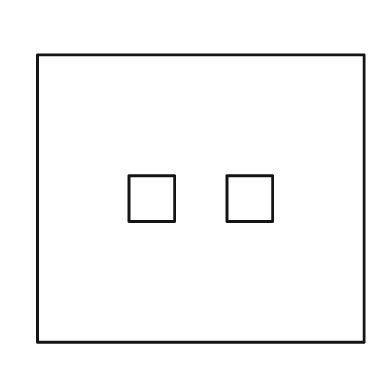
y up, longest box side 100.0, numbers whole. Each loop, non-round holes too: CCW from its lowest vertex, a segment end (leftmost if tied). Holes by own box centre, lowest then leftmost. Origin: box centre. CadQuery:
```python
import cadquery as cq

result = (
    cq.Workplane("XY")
    .moveTo(-50.0, -44.0)
    .lineTo(50.0, -44.0)
    .lineTo(50.0, 44.0)
    .lineTo(-50.0, 44.0)
    .close()
    .moveTo(-22.0, -7.0)
    .lineTo(-8.0, -7.0)
    .lineTo(-8.0, 7.0)
    .lineTo(-22.0, 7.0)
    .close()
    .moveTo(8.0, -7.0)
    .lineTo(22.0, -7.0)
    .lineTo(22.0, 7.0)
    .lineTo(8.0, 7.0)
    .close()
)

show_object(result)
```